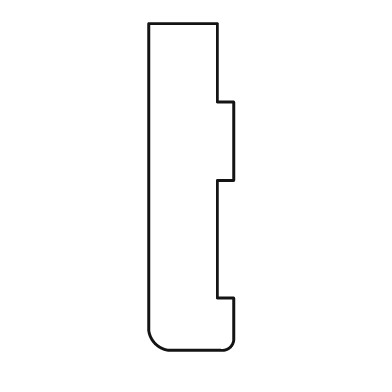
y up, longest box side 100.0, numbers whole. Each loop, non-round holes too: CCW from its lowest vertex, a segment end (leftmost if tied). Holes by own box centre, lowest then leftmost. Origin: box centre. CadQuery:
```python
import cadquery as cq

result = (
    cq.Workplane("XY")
    .moveTo(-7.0, -50.0)
    .lineTo(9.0, -50.0)
    .threePointArc((12.0, -49.0), (13.0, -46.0))
    .lineTo(13.0, -34.0)
    .lineTo(8.0, -34.0)
    .lineTo(8.0, 2.0)
    .lineTo(13.0, 2.0)
    .lineTo(13.0, 26.0)
    .lineTo(8.0, 26.0)
    .lineTo(8.0, 50.0)
    .lineTo(-13.0, 50.0)
    .lineTo(-13.0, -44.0)
    .threePointArc((-11.0, -48.0), (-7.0, -50.0))
    .close()
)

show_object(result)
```